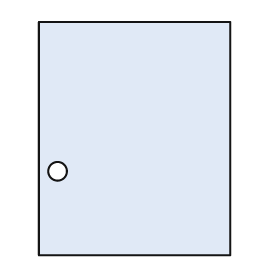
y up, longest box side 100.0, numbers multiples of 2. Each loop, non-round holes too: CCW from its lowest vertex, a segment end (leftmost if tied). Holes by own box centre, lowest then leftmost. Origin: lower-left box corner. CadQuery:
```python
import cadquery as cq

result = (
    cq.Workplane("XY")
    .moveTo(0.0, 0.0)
    .lineTo(82.0, 0.0)
    .lineTo(82.0, 100.0)
    .lineTo(0.0, 100.0)
    .close()
    .moveTo(8.0, 36.0)
    .circle(4.0)
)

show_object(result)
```